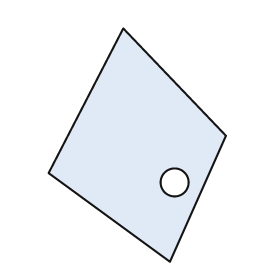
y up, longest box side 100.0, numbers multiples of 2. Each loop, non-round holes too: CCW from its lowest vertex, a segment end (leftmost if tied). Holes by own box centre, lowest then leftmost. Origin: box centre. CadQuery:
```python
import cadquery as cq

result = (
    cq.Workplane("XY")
    .moveTo(14.0, -50.0)
    .lineTo(38.0, 4.0)
    .lineTo(-6.0, 50.0)
    .lineTo(-38.0, -12.0)
    .close()
    .moveTo(16.0, -16.0)
    .circle(6.0)
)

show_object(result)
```